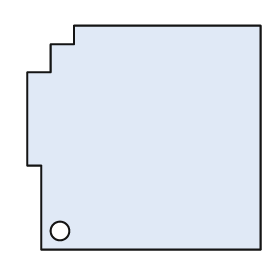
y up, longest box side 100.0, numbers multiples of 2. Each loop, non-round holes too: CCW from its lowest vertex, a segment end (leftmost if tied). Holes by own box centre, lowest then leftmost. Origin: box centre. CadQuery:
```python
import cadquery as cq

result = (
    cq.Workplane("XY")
    .moveTo(-44.0, -48.0)
    .lineTo(50.0, -48.0)
    .lineTo(50.0, 48.0)
    .lineTo(-30.0, 48.0)
    .lineTo(-30.0, 40.0)
    .lineTo(-40.0, 40.0)
    .lineTo(-40.0, 28.0)
    .lineTo(-50.0, 28.0)
    .lineTo(-50.0, -12.0)
    .lineTo(-44.0, -12.0)
    .close()
    .moveTo(-36.0, -40.0)
    .circle(4.0)
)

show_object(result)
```